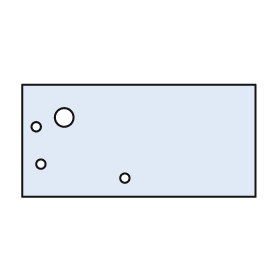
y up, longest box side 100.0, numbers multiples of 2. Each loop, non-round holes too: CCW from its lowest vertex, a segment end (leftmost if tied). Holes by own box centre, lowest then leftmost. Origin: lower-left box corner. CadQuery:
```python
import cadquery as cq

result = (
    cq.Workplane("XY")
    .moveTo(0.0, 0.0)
    .lineTo(100.0, 0.0)
    .lineTo(100.0, 48.0)
    .lineTo(0.0, 48.0)
    .close()
    .moveTo(44.0, 8.0)
    .circle(2.0)
    .moveTo(8.0, 14.0)
    .circle(2.0)
    .moveTo(6.0, 30.0)
    .circle(2.0)
    .moveTo(18.0, 34.0)
    .circle(4.0)
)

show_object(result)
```